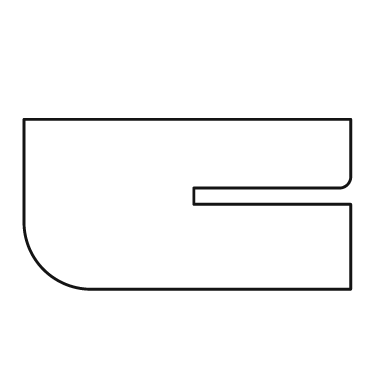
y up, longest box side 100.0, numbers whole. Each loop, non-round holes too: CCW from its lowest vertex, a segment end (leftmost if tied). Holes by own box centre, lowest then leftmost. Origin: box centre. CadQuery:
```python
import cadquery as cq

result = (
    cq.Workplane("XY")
    .moveTo(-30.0, -26.0)
    .lineTo(50.0, -26.0)
    .lineTo(50.0, 0.0)
    .lineTo(2.0, 0.0)
    .lineTo(2.0, 5.0)
    .lineTo(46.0, 5.0)
    .threePointArc((49.0, 6.0), (50.0, 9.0))
    .lineTo(50.0, 26.0)
    .lineTo(-50.0, 26.0)
    .lineTo(-50.0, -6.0)
    .threePointArc((-44.0, -20.0), (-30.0, -26.0))
    .close()
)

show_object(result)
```